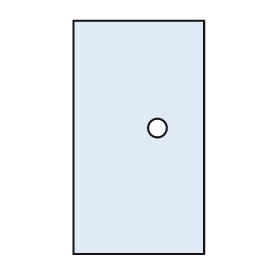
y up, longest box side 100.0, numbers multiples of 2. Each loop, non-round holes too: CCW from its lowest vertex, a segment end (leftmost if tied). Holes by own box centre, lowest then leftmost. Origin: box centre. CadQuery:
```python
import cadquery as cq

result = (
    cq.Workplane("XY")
    .moveTo(-28.0, -50.0)
    .lineTo(28.0, -50.0)
    .lineTo(28.0, 50.0)
    .lineTo(-28.0, 50.0)
    .close()
    .moveTo(8.0, 4.0)
    .circle(4.0)
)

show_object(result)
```